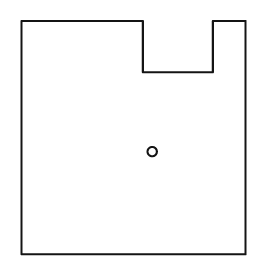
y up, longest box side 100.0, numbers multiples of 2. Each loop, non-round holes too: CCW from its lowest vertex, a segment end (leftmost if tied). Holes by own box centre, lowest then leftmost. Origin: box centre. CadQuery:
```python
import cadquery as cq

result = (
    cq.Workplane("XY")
    .moveTo(-48.0, -50.0)
    .lineTo(48.0, -50.0)
    .lineTo(48.0, 50.0)
    .lineTo(34.0, 50.0)
    .lineTo(34.0, 28.0)
    .lineTo(4.0, 28.0)
    .lineTo(4.0, 50.0)
    .lineTo(-48.0, 50.0)
    .close()
    .moveTo(8.0, -6.0)
    .circle(2.0)
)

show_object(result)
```